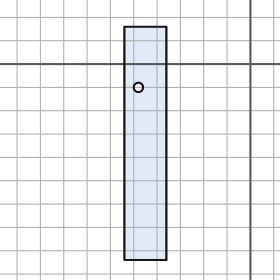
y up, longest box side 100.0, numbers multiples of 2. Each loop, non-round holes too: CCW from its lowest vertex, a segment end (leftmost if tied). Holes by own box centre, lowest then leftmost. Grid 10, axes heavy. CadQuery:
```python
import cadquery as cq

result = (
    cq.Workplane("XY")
    .moveTo(-54.0, -84.0)
    .lineTo(-36.0, -84.0)
    .lineTo(-36.0, 16.0)
    .lineTo(-54.0, 16.0)
    .close()
    .moveTo(-48.0, -10.0)
    .circle(2.0)
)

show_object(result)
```